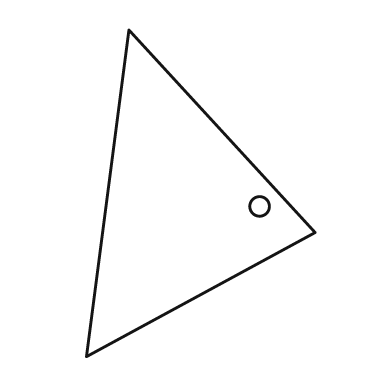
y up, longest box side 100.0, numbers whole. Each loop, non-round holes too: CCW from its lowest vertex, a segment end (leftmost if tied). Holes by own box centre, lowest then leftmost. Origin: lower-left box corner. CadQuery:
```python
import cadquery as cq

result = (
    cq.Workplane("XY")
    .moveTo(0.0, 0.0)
    .lineTo(70.0, 38.0)
    .lineTo(13.0, 100.0)
    .close()
    .moveTo(53.0, 46.0)
    .circle(3.0)
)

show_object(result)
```